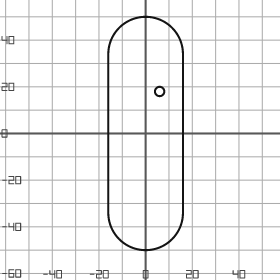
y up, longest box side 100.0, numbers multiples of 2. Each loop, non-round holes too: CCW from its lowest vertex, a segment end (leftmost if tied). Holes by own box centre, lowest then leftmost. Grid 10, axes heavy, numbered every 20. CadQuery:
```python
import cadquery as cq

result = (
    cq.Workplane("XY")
    .moveTo(-16.0, -34.0)
    .threePointArc((0.0, -50.0), (16.0, -34.0))
    .lineTo(16.0, 34.0)
    .threePointArc((0.0, 50.0), (-16.0, 34.0))
    .close()
    .moveTo(6.0, 18.0)
    .circle(2.0)
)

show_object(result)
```